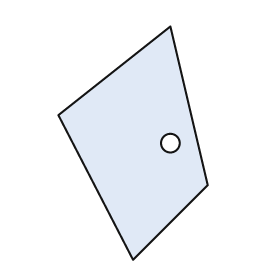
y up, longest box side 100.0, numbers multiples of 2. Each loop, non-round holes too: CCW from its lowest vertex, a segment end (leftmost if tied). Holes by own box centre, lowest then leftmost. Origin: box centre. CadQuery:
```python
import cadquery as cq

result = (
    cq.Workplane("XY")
    .moveTo(0.0, -50.0)
    .lineTo(32.0, -18.0)
    .lineTo(16.0, 50.0)
    .lineTo(-32.0, 12.0)
    .close()
    .moveTo(16.0, 0.0)
    .circle(4.0)
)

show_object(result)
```